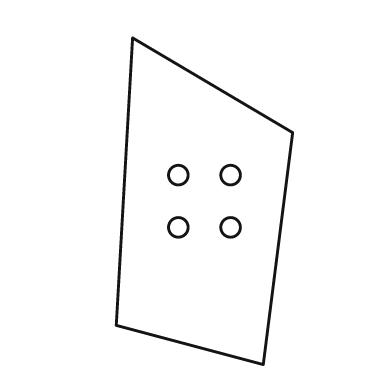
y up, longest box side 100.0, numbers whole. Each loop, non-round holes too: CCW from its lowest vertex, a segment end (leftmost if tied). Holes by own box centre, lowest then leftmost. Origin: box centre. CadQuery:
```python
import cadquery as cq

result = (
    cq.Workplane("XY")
    .moveTo(18.0, -50.0)
    .lineTo(27.0, 21.0)
    .lineTo(-22.0, 50.0)
    .lineTo(-27.0, -38.0)
    .close()
    .moveTo(-8.0, -8.0)
    .circle(3.0)
    .moveTo(8.0, -8.0)
    .circle(3.0)
    .moveTo(-8.0, 8.0)
    .circle(3.0)
    .moveTo(8.0, 8.0)
    .circle(3.0)
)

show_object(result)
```